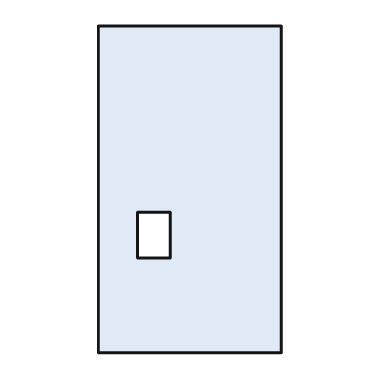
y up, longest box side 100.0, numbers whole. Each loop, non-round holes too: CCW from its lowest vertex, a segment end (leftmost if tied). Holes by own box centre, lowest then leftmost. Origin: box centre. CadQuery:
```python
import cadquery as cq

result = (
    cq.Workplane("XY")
    .moveTo(-28.0, -50.0)
    .lineTo(28.0, -50.0)
    .lineTo(28.0, 50.0)
    .lineTo(-28.0, 50.0)
    .close()
    .moveTo(-16.0, -21.0)
    .lineTo(-6.0, -21.0)
    .lineTo(-6.0, -7.0)
    .lineTo(-16.0, -7.0)
    .close()
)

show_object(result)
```